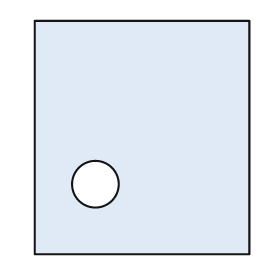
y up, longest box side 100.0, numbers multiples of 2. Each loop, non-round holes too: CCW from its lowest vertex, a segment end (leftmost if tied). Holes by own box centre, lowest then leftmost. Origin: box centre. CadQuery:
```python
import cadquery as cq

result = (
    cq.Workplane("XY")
    .moveTo(-46.0, -50.0)
    .lineTo(46.0, -50.0)
    .lineTo(46.0, 50.0)
    .lineTo(-46.0, 50.0)
    .close()
    .moveTo(-20.0, -20.0)
    .circle(10.0)
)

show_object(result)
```